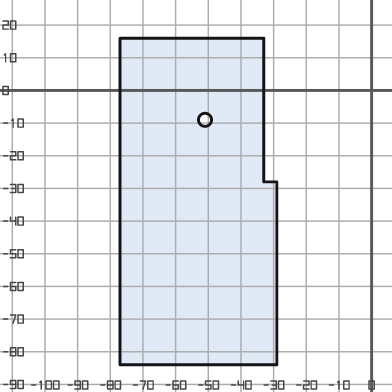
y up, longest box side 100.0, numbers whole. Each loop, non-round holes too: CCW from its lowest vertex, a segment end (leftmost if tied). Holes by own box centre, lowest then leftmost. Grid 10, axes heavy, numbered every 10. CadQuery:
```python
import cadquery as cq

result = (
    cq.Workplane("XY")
    .moveTo(-77.0, -84.0)
    .lineTo(-29.0, -84.0)
    .lineTo(-29.0, -28.0)
    .lineTo(-33.0, -28.0)
    .lineTo(-33.0, 16.0)
    .lineTo(-77.0, 16.0)
    .close()
    .moveTo(-51.0, -9.0)
    .circle(2.0)
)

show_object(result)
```